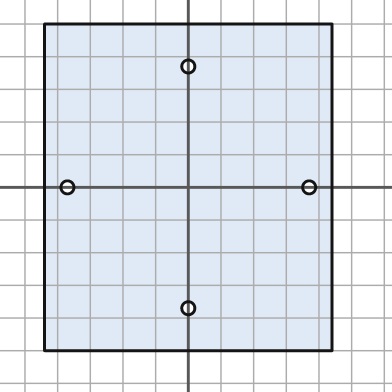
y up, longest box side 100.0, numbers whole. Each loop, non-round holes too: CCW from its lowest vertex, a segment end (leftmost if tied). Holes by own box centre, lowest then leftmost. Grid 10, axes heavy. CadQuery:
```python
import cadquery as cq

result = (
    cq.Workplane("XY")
    .moveTo(-44.0, -50.0)
    .lineTo(44.0, -50.0)
    .lineTo(44.0, 50.0)
    .lineTo(-44.0, 50.0)
    .close()
    .moveTo(0.0, -37.0)
    .circle(2.0)
    .moveTo(-37.0, 0.0)
    .circle(2.0)
    .moveTo(37.0, 0.0)
    .circle(2.0)
    .moveTo(0.0, 37.0)
    .circle(2.0)
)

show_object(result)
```